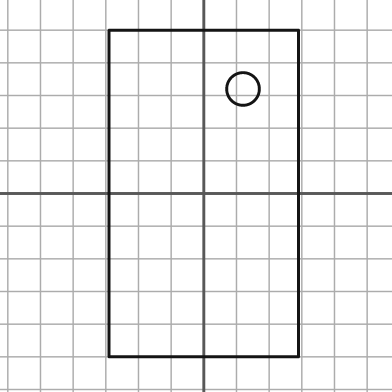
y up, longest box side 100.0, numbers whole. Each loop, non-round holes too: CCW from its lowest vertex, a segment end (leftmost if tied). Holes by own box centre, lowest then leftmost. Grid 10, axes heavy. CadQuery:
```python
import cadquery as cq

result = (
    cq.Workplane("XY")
    .moveTo(-29.0, -50.0)
    .lineTo(29.0, -50.0)
    .lineTo(29.0, 50.0)
    .lineTo(-29.0, 50.0)
    .close()
    .moveTo(12.0, 32.0)
    .circle(5.0)
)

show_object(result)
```